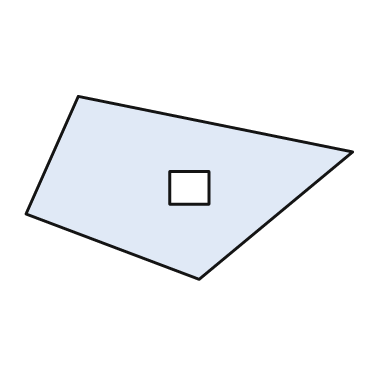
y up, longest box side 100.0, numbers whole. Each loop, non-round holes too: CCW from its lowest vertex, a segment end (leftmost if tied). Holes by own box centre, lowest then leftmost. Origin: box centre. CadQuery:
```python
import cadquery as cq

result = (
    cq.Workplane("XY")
    .moveTo(3.0, -28.0)
    .lineTo(50.0, 11.0)
    .lineTo(-34.0, 28.0)
    .lineTo(-50.0, -8.0)
    .close()
    .moveTo(-6.0, -5.0)
    .lineTo(6.0, -5.0)
    .lineTo(6.0, 5.0)
    .lineTo(-6.0, 5.0)
    .close()
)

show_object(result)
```